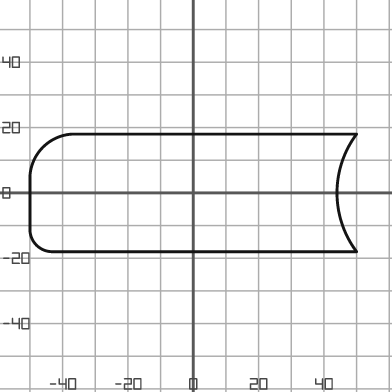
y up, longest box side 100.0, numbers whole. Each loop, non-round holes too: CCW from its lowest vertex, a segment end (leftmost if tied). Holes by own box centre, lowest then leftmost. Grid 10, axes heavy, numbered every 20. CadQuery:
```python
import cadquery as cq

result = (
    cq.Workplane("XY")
    .moveTo(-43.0, -18.0)
    .lineTo(50.0, -18.0)
    .threePointArc((44.0, 0.0), (50.0, 18.0))
    .lineTo(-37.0, 18.0)
    .threePointArc((-46.0, 14.0), (-50.0, 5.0))
    .lineTo(-50.0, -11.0)
    .threePointArc((-48.0, -16.0), (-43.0, -18.0))
    .close()
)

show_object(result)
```